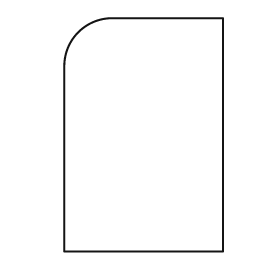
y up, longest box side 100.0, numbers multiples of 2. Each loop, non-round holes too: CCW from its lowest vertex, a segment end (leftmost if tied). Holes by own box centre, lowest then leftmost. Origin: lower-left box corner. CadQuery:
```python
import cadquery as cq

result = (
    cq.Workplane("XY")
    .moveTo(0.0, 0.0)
    .lineTo(68.0, 0.0)
    .lineTo(68.0, 100.0)
    .lineTo(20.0, 100.0)
    .threePointArc((6.0, 94.0), (0.0, 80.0))
    .close()
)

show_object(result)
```